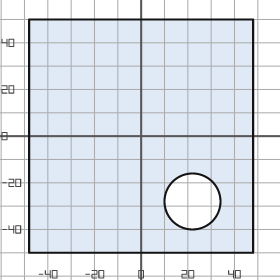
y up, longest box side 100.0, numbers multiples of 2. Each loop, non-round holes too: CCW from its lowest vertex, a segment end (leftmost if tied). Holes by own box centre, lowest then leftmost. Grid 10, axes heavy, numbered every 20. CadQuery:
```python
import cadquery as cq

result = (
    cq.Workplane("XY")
    .moveTo(-48.0, -50.0)
    .lineTo(48.0, -50.0)
    .lineTo(48.0, 50.0)
    .lineTo(-48.0, 50.0)
    .close()
    .moveTo(22.0, -28.0)
    .circle(12.0)
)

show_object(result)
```